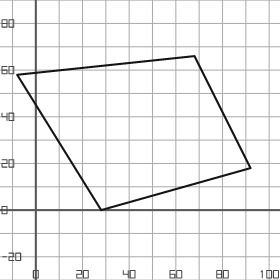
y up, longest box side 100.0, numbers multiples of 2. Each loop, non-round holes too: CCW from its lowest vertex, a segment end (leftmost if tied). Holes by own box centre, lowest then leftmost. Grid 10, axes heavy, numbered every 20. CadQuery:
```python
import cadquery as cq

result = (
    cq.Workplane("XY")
    .moveTo(28.0, 0.0)
    .lineTo(92.0, 18.0)
    .lineTo(68.0, 66.0)
    .lineTo(-8.0, 58.0)
    .close()
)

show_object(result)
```